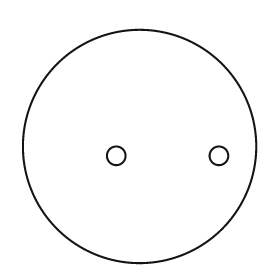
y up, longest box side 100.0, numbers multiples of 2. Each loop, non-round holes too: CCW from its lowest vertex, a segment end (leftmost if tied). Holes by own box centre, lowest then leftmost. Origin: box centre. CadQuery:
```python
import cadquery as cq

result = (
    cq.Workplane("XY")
    .moveTo(0.0, 0.0)
    .circle(50.0)
    .moveTo(-10.0, -4.0)
    .circle(4.0)
    .moveTo(34.0, -4.0)
    .circle(4.0)
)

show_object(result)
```